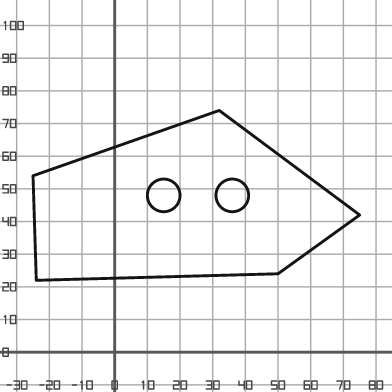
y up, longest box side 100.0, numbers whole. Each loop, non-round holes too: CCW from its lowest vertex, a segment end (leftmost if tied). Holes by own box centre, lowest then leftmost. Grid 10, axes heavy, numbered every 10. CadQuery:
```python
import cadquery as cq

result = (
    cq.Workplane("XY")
    .moveTo(-24.0, 22.0)
    .lineTo(50.0, 24.0)
    .lineTo(75.0, 42.0)
    .lineTo(32.0, 74.0)
    .lineTo(-25.0, 54.0)
    .close()
    .moveTo(15.0, 48.0)
    .circle(5.0)
    .moveTo(36.0, 48.0)
    .circle(5.0)
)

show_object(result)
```